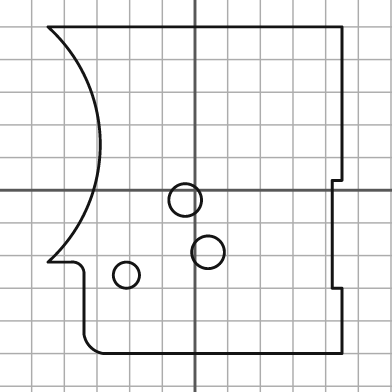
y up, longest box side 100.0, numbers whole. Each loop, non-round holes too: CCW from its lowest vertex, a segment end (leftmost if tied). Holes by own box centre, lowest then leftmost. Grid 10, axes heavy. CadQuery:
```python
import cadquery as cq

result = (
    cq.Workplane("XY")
    .moveTo(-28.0, -50.0)
    .lineTo(45.0, -50.0)
    .lineTo(45.0, -30.0)
    .lineTo(42.0, -30.0)
    .lineTo(42.0, 3.0)
    .lineTo(45.0, 3.0)
    .lineTo(45.0, 50.0)
    .lineTo(-45.0, 50.0)
    .threePointArc((-29.0, 14.0), (-45.0, -22.0))
    .lineTo(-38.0, -22.0)
    .threePointArc((-35.0, -23.0), (-34.0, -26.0))
    .lineTo(-34.0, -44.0)
    .threePointArc((-32.0, -48.0), (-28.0, -50.0))
    .close()
    .moveTo(-21.0, -26.0)
    .circle(4.0)
    .moveTo(4.0, -19.0)
    .circle(5.0)
    .moveTo(-3.0, -3.0)
    .circle(5.0)
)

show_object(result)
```